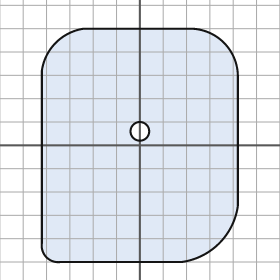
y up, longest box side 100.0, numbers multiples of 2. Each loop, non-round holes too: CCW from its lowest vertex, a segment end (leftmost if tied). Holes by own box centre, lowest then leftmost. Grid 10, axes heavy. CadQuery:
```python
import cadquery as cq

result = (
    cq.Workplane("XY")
    .moveTo(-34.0, -50.0)
    .lineTo(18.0, -50.0)
    .threePointArc((34.0, -42.0), (42.0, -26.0))
    .lineTo(42.0, 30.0)
    .threePointArc((36.0, 44.0), (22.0, 50.0))
    .lineTo(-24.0, 50.0)
    .threePointArc((-36.0, 44.0), (-42.0, 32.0))
    .lineTo(-42.0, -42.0)
    .threePointArc((-40.0, -48.0), (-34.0, -50.0))
    .close()
    .moveTo(0.0, 6.0)
    .circle(4.0)
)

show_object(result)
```